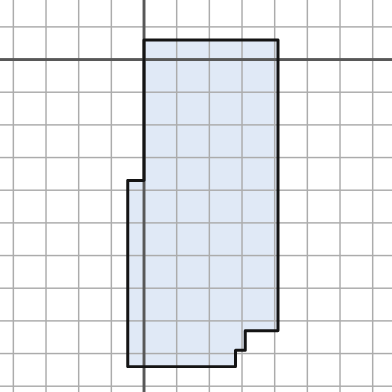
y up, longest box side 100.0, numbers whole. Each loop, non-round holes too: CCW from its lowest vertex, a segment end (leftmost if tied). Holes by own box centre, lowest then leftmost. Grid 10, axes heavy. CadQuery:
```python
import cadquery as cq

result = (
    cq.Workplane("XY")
    .moveTo(-5.0, -94.0)
    .lineTo(28.0, -94.0)
    .lineTo(28.0, -89.0)
    .lineTo(31.0, -89.0)
    .lineTo(31.0, -83.0)
    .lineTo(41.0, -83.0)
    .lineTo(41.0, 6.0)
    .lineTo(0.0, 6.0)
    .lineTo(0.0, -37.0)
    .lineTo(-5.0, -37.0)
    .close()
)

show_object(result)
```